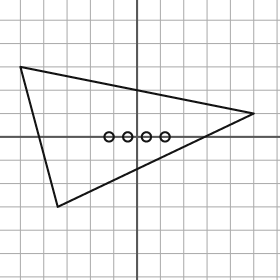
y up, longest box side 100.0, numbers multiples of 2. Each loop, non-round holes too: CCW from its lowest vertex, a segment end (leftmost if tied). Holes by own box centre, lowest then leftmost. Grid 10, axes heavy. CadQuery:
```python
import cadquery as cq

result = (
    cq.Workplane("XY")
    .moveTo(-34.0, -30.0)
    .lineTo(50.0, 10.0)
    .lineTo(-50.0, 30.0)
    .close()
    .moveTo(-12.0, 0.0)
    .circle(2.0)
    .moveTo(-4.0, 0.0)
    .circle(2.0)
    .moveTo(4.0, 0.0)
    .circle(2.0)
    .moveTo(12.0, 0.0)
    .circle(2.0)
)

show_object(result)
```